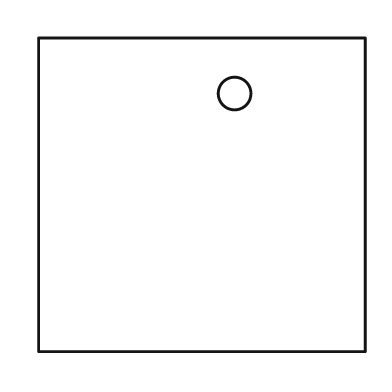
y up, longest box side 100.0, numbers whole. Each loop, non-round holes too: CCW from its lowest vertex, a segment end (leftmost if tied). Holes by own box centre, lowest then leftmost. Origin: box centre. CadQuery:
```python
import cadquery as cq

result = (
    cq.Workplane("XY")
    .moveTo(-50.0, -48.0)
    .lineTo(50.0, -48.0)
    .lineTo(50.0, 48.0)
    .lineTo(-50.0, 48.0)
    .close()
    .moveTo(10.0, 31.0)
    .circle(5.0)
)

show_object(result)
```